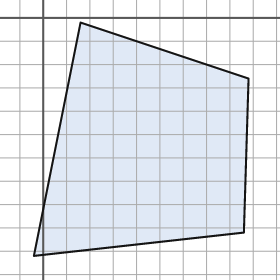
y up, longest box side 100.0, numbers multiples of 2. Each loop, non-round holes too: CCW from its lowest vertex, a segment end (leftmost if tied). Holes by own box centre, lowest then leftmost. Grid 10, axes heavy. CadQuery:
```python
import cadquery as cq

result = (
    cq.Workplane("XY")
    .moveTo(-4.0, -102.0)
    .lineTo(86.0, -92.0)
    .lineTo(88.0, -26.0)
    .lineTo(16.0, -2.0)
    .close()
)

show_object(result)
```